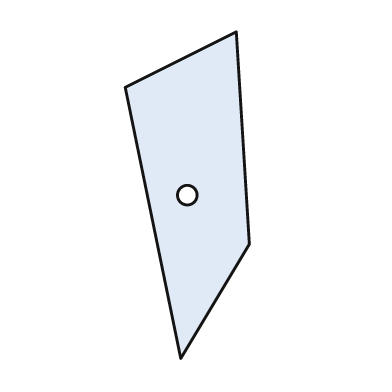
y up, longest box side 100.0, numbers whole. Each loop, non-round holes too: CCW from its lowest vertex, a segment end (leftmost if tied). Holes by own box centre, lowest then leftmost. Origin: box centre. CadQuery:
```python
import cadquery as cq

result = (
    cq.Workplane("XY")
    .moveTo(-2.0, -50.0)
    .lineTo(19.0, -15.0)
    .lineTo(15.0, 50.0)
    .lineTo(-19.0, 33.0)
    .close()
    .moveTo(0.0, 0.0)
    .circle(3.0)
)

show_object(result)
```